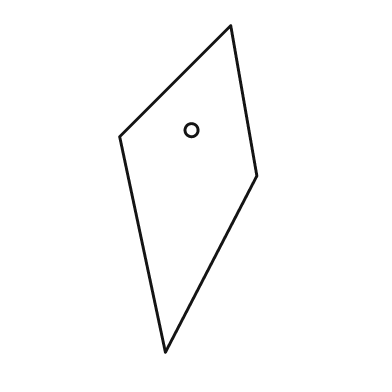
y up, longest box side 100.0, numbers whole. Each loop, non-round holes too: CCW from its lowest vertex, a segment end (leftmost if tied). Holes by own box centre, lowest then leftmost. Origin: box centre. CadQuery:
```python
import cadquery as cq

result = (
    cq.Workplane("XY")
    .moveTo(-7.0, -50.0)
    .lineTo(21.0, 4.0)
    .lineTo(13.0, 50.0)
    .lineTo(-21.0, 16.0)
    .close()
    .moveTo(1.0, 18.0)
    .circle(2.0)
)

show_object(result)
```